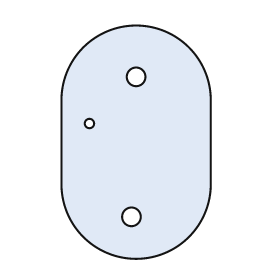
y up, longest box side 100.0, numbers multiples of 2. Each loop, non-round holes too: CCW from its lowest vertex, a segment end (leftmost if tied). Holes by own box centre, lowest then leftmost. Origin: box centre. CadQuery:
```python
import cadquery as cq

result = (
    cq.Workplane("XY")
    .moveTo(-32.0, -18.0)
    .threePointArc((0.0, -50.0), (32.0, -18.0))
    .lineTo(32.0, 18.0)
    .threePointArc((0.0, 50.0), (-32.0, 18.0))
    .close()
    .moveTo(-2.0, -32.0)
    .circle(4.0)
    .moveTo(-20.0, 8.0)
    .circle(2.0)
    .moveTo(0.0, 28.0)
    .circle(4.0)
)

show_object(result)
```